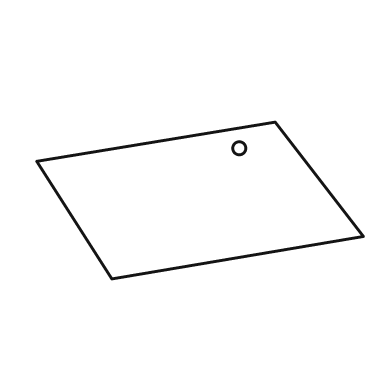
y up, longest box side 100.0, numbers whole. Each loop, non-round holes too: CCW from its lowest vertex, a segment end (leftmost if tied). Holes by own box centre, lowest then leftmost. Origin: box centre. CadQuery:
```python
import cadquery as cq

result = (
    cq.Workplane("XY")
    .moveTo(-27.0, -24.0)
    .lineTo(50.0, -11.0)
    .lineTo(23.0, 24.0)
    .lineTo(-50.0, 12.0)
    .close()
    .moveTo(12.0, 16.0)
    .circle(2.0)
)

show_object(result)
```